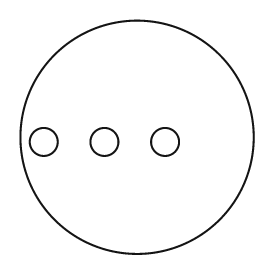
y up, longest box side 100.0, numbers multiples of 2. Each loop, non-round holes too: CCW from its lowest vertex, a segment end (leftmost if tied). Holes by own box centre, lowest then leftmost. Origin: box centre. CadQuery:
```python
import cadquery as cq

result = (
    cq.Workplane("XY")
    .moveTo(0.0, 0.0)
    .circle(50.0)
    .moveTo(-40.0, -2.0)
    .circle(6.0)
    .moveTo(-14.0, -2.0)
    .circle(6.0)
    .moveTo(12.0, -2.0)
    .circle(6.0)
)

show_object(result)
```